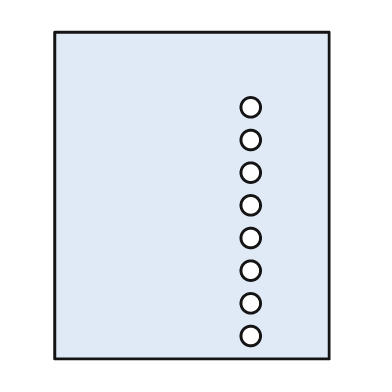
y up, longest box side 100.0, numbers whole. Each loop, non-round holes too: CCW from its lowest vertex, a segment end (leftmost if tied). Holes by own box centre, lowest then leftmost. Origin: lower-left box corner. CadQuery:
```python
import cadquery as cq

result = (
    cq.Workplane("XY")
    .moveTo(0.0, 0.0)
    .lineTo(84.0, 0.0)
    .lineTo(84.0, 100.0)
    .lineTo(0.0, 100.0)
    .close()
    .moveTo(60.0, 7.0)
    .circle(3.0)
    .moveTo(60.0, 17.0)
    .circle(3.0)
    .moveTo(60.0, 27.0)
    .circle(3.0)
    .moveTo(60.0, 37.0)
    .circle(3.0)
    .moveTo(60.0, 47.0)
    .circle(3.0)
    .moveTo(60.0, 57.0)
    .circle(3.0)
    .moveTo(60.0, 67.0)
    .circle(3.0)
    .moveTo(60.0, 77.0)
    .circle(3.0)
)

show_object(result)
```